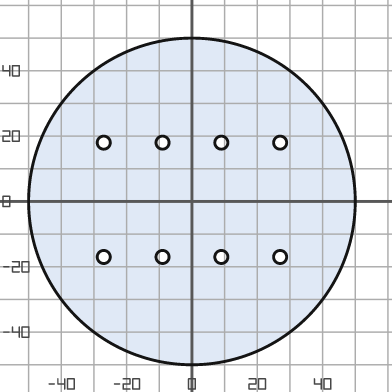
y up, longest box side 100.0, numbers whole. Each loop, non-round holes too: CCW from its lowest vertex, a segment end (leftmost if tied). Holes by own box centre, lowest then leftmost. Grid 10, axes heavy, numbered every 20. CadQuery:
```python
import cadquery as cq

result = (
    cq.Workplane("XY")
    .moveTo(0.0, 0.0)
    .circle(50.0)
    .moveTo(-27.0, -17.0)
    .circle(2.0)
    .moveTo(-9.0, -17.0)
    .circle(2.0)
    .moveTo(9.0, -17.0)
    .circle(2.0)
    .moveTo(27.0, -17.0)
    .circle(2.0)
    .moveTo(-27.0, 18.0)
    .circle(2.0)
    .moveTo(-9.0, 18.0)
    .circle(2.0)
    .moveTo(9.0, 18.0)
    .circle(2.0)
    .moveTo(27.0, 18.0)
    .circle(2.0)
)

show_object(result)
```